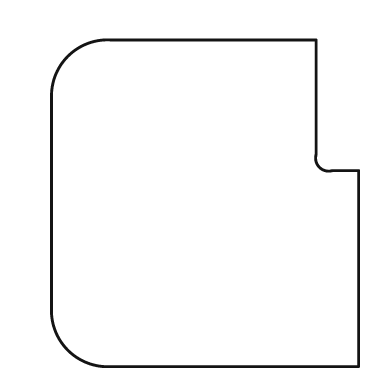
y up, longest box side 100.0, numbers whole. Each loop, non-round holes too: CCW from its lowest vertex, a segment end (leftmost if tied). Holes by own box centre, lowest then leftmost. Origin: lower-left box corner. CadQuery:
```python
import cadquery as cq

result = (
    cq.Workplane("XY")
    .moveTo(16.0, 0.0)
    .lineTo(94.0, 0.0)
    .lineTo(94.0, 60.0)
    .lineTo(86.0, 60.0)
    .threePointArc((82.0, 61.0), (81.0, 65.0))
    .lineTo(81.0, 100.0)
    .lineTo(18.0, 100.0)
    .threePointArc((5.0, 95.0), (0.0, 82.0))
    .lineTo(0.0, 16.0)
    .threePointArc((5.0, 5.0), (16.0, 0.0))
    .close()
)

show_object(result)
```